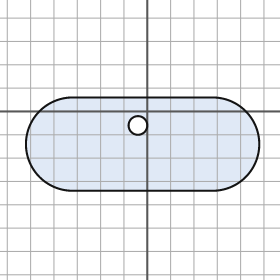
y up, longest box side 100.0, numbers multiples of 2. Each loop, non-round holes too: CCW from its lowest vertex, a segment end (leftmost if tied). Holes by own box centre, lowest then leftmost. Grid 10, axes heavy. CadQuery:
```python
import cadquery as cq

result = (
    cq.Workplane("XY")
    .moveTo(-32.0, -34.0)
    .lineTo(28.0, -34.0)
    .threePointArc((48.0, -14.0), (28.0, 6.0))
    .lineTo(-32.0, 6.0)
    .threePointArc((-52.0, -14.0), (-32.0, -34.0))
    .close()
    .moveTo(-4.0, -6.0)
    .circle(4.0)
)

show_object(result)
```